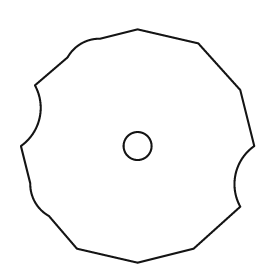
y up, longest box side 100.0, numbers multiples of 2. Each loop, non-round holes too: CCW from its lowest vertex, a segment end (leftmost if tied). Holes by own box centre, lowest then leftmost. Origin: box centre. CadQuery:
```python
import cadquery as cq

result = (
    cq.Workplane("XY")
    .moveTo(0.0, -50.0)
    .lineTo(24.0, -44.0)
    .lineTo(44.0, -26.0)
    .threePointArc((42.0, -12.0), (50.0, 0.0))
    .lineTo(44.0, 24.0)
    .lineTo(26.0, 44.0)
    .lineTo(0.0, 50.0)
    .lineTo(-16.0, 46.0)
    .threePointArc((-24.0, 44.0), (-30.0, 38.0))
    .lineTo(-44.0, 26.0)
    .threePointArc((-42.0, 12.0), (-50.0, 0.0))
    .lineTo(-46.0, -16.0)
    .threePointArc((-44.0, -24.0), (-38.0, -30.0))
    .lineTo(-26.0, -44.0)
    .close()
    .moveTo(0.0, 0.0)
    .circle(6.0)
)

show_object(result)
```